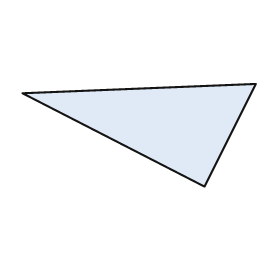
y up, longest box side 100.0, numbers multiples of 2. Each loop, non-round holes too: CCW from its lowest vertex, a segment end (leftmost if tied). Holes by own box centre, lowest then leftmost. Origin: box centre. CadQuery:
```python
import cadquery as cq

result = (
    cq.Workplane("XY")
    .moveTo(28.0, -22.0)
    .lineTo(50.0, 22.0)
    .lineTo(-50.0, 18.0)
    .close()
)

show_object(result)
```